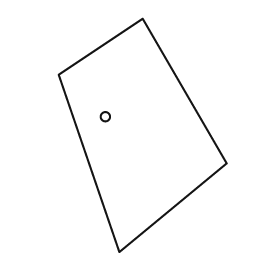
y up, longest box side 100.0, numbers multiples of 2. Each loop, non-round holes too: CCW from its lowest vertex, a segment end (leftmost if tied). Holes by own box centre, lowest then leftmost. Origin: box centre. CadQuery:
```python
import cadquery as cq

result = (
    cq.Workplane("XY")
    .moveTo(-10.0, -50.0)
    .lineTo(36.0, -12.0)
    .lineTo(0.0, 50.0)
    .lineTo(-36.0, 26.0)
    .close()
    .moveTo(-16.0, 8.0)
    .circle(2.0)
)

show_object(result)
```